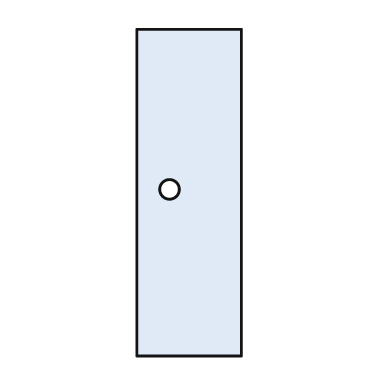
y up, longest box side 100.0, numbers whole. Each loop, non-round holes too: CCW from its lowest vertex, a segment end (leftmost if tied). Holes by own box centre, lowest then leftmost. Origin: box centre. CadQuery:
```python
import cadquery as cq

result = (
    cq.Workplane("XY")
    .moveTo(-16.0, -50.0)
    .lineTo(16.0, -50.0)
    .lineTo(16.0, 50.0)
    .lineTo(-16.0, 50.0)
    .close()
    .moveTo(-6.0, 1.0)
    .circle(3.0)
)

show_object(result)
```